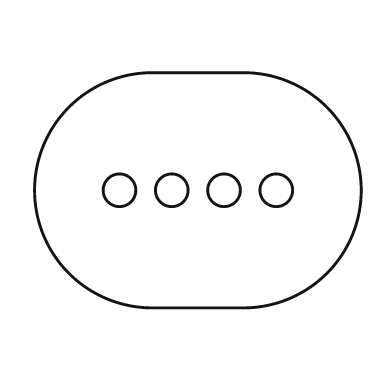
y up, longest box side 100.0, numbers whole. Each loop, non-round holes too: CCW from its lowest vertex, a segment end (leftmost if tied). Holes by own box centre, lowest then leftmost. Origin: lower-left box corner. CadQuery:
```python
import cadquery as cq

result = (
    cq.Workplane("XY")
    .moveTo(36.0, 0.0)
    .lineTo(64.0, 0.0)
    .threePointArc((100.0, 36.0), (64.0, 72.0))
    .lineTo(36.0, 72.0)
    .threePointArc((0.0, 36.0), (36.0, 0.0))
    .close()
    .moveTo(26.0, 36.0)
    .circle(5.0)
    .moveTo(42.0, 36.0)
    .circle(5.0)
    .moveTo(58.0, 36.0)
    .circle(5.0)
    .moveTo(74.0, 36.0)
    .circle(5.0)
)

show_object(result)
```